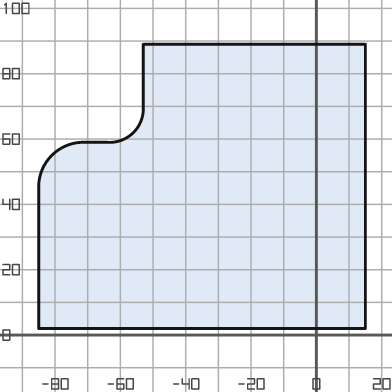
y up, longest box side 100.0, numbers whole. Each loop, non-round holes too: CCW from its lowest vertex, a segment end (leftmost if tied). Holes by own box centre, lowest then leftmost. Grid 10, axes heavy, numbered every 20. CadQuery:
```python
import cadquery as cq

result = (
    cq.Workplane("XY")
    .moveTo(-85.0, 2.0)
    .lineTo(15.0, 2.0)
    .lineTo(15.0, 89.0)
    .lineTo(-53.0, 89.0)
    .lineTo(-53.0, 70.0)
    .threePointArc((-56.0, 62.0), (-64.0, 59.0))
    .lineTo(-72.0, 59.0)
    .threePointArc((-81.0, 55.0), (-85.0, 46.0))
    .close()
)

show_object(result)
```